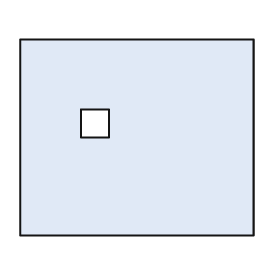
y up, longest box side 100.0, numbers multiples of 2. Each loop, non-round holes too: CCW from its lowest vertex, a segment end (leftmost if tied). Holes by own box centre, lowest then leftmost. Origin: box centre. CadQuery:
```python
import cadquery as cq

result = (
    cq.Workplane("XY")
    .moveTo(-50.0, -42.0)
    .lineTo(50.0, -42.0)
    .lineTo(50.0, 42.0)
    .lineTo(-50.0, 42.0)
    .close()
    .moveTo(-24.0, 0.0)
    .lineTo(-12.0, 0.0)
    .lineTo(-12.0, 12.0)
    .lineTo(-24.0, 12.0)
    .close()
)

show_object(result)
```